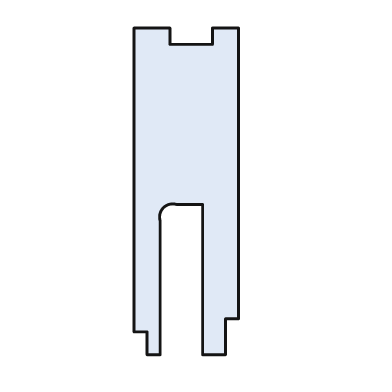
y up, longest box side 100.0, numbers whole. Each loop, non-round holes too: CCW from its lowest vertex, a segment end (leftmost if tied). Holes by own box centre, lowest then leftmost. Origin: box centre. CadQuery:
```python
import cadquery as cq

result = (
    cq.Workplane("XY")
    .moveTo(-12.0, -50.0)
    .lineTo(-8.0, -50.0)
    .lineTo(-8.0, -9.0)
    .threePointArc((-7.0, -5.0), (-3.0, -4.0))
    .lineTo(5.0, -4.0)
    .lineTo(5.0, -50.0)
    .lineTo(12.0, -50.0)
    .lineTo(12.0, -39.0)
    .lineTo(16.0, -39.0)
    .lineTo(16.0, 50.0)
    .lineTo(8.0, 50.0)
    .lineTo(8.0, 45.0)
    .lineTo(-5.0, 45.0)
    .lineTo(-5.0, 50.0)
    .lineTo(-16.0, 50.0)
    .lineTo(-16.0, -43.0)
    .lineTo(-12.0, -43.0)
    .close()
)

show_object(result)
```